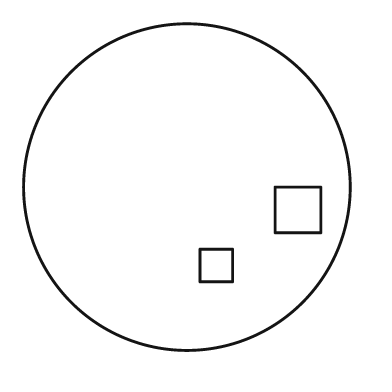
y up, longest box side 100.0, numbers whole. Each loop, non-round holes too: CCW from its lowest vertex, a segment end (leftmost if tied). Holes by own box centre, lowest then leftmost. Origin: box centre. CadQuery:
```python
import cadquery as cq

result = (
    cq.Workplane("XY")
    .moveTo(0.0, 0.0)
    .circle(50.0)
    .moveTo(4.0, -29.0)
    .lineTo(14.0, -29.0)
    .lineTo(14.0, -19.0)
    .lineTo(4.0, -19.0)
    .close()
    .moveTo(27.0, -14.0)
    .lineTo(41.0, -14.0)
    .lineTo(41.0, 0.0)
    .lineTo(27.0, 0.0)
    .close()
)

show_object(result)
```